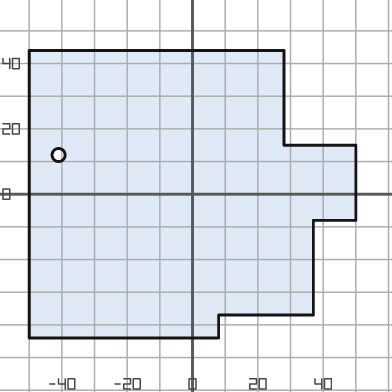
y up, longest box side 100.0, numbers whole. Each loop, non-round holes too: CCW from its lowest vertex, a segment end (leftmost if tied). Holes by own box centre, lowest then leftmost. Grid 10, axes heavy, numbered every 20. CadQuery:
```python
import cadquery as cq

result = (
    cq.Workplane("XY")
    .moveTo(-50.0, -44.0)
    .lineTo(8.0, -44.0)
    .lineTo(8.0, -37.0)
    .lineTo(37.0, -37.0)
    .lineTo(37.0, -8.0)
    .lineTo(50.0, -8.0)
    .lineTo(50.0, 15.0)
    .lineTo(28.0, 15.0)
    .lineTo(28.0, 44.0)
    .lineTo(-50.0, 44.0)
    .close()
    .moveTo(-41.0, 12.0)
    .circle(2.0)
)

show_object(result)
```